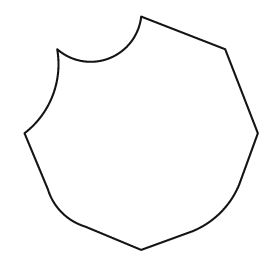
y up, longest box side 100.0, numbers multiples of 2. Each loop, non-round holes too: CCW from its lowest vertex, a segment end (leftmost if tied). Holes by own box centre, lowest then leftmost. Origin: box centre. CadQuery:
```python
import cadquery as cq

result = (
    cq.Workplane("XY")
    .moveTo(0.0, -50.0)
    .lineTo(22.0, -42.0)
    .threePointArc((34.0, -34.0), (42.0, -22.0))
    .lineTo(50.0, 0.0)
    .lineTo(36.0, 36.0)
    .lineTo(0.0, 50.0)
    .threePointArc((-14.0, 32.0), (-36.0, 36.0))
    .threePointArc((-38.0, 16.0), (-50.0, 0.0))
    .lineTo(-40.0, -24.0)
    .threePointArc((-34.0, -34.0), (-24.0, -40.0))
    .close()
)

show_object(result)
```